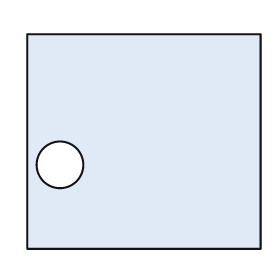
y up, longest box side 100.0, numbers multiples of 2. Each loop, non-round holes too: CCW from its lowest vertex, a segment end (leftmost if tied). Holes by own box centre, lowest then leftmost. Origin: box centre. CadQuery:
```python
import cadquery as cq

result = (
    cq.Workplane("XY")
    .moveTo(-50.0, -46.0)
    .lineTo(50.0, -46.0)
    .lineTo(50.0, 46.0)
    .lineTo(-50.0, 46.0)
    .close()
    .moveTo(-36.0, -10.0)
    .circle(10.0)
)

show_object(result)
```